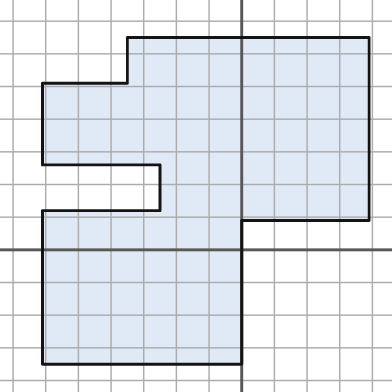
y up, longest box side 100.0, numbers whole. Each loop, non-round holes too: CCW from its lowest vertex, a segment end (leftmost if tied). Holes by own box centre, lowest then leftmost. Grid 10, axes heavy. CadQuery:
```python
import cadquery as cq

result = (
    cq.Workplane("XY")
    .moveTo(-61.0, -35.0)
    .lineTo(0.0, -35.0)
    .lineTo(0.0, 9.0)
    .lineTo(39.0, 9.0)
    .lineTo(39.0, 65.0)
    .lineTo(-35.0, 65.0)
    .lineTo(-35.0, 51.0)
    .lineTo(-61.0, 51.0)
    .lineTo(-61.0, 26.0)
    .lineTo(-25.0, 26.0)
    .lineTo(-25.0, 12.0)
    .lineTo(-61.0, 12.0)
    .close()
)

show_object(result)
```